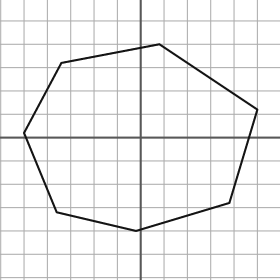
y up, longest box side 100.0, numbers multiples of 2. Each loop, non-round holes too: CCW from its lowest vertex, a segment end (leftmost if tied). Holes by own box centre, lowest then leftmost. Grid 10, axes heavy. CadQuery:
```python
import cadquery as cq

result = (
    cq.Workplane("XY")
    .moveTo(-2.0, -40.0)
    .lineTo(38.0, -28.0)
    .lineTo(50.0, 12.0)
    .lineTo(8.0, 40.0)
    .lineTo(-34.0, 32.0)
    .lineTo(-50.0, 2.0)
    .lineTo(-36.0, -32.0)
    .close()
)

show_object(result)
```